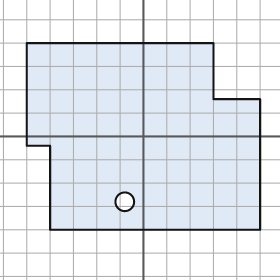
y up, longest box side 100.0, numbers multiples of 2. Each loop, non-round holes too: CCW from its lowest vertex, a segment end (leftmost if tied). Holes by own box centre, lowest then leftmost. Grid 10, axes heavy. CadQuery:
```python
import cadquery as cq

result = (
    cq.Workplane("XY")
    .moveTo(-40.0, -40.0)
    .lineTo(50.0, -40.0)
    .lineTo(50.0, 16.0)
    .lineTo(30.0, 16.0)
    .lineTo(30.0, 40.0)
    .lineTo(-50.0, 40.0)
    .lineTo(-50.0, -4.0)
    .lineTo(-40.0, -4.0)
    .close()
    .moveTo(-8.0, -28.0)
    .circle(4.0)
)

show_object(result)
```